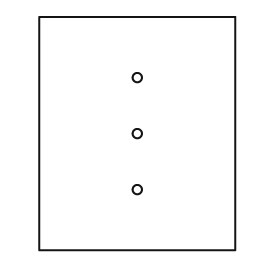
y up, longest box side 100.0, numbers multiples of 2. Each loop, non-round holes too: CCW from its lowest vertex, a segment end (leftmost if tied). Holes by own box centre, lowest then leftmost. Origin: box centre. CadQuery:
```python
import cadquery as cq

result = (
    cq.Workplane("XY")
    .moveTo(-42.0, -50.0)
    .lineTo(42.0, -50.0)
    .lineTo(42.0, 50.0)
    .lineTo(-42.0, 50.0)
    .close()
    .moveTo(0.0, -24.0)
    .circle(2.0)
    .moveTo(0.0, 0.0)
    .circle(2.0)
    .moveTo(0.0, 24.0)
    .circle(2.0)
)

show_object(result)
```